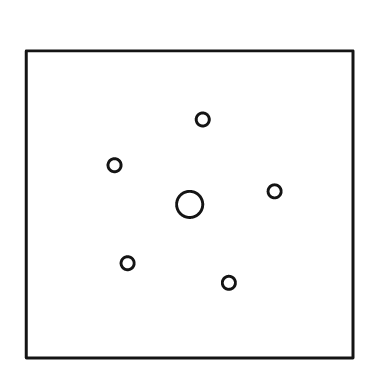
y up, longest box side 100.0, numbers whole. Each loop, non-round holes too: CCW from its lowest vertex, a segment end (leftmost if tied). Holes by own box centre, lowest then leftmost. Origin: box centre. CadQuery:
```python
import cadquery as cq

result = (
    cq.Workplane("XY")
    .moveTo(-50.0, -47.0)
    .lineTo(50.0, -47.0)
    .lineTo(50.0, 47.0)
    .lineTo(-50.0, 47.0)
    .close()
    .moveTo(12.0, -24.0)
    .circle(2.0)
    .moveTo(-19.0, -18.0)
    .circle(2.0)
    .moveTo(0.0, 0.0)
    .circle(4.0)
    .moveTo(26.0, 4.0)
    .circle(2.0)
    .moveTo(-23.0, 12.0)
    .circle(2.0)
    .moveTo(4.0, 26.0)
    .circle(2.0)
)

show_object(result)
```